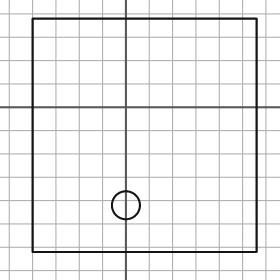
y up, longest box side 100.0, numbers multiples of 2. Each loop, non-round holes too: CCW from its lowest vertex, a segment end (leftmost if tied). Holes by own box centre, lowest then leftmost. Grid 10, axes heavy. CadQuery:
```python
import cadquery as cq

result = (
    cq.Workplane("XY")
    .moveTo(-40.0, -62.0)
    .lineTo(56.0, -62.0)
    .lineTo(56.0, 38.0)
    .lineTo(-40.0, 38.0)
    .close()
    .moveTo(0.0, -42.0)
    .circle(6.0)
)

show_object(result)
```